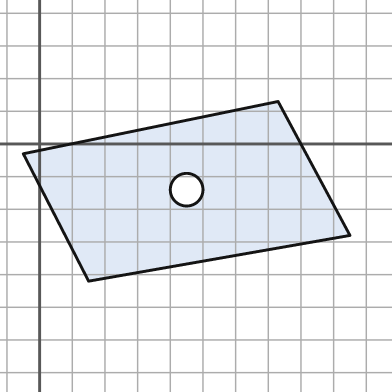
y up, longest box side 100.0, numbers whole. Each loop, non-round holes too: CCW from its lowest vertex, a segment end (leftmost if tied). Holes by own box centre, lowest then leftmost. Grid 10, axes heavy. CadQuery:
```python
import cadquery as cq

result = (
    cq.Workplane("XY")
    .moveTo(15.0, -42.0)
    .lineTo(95.0, -28.0)
    .lineTo(73.0, 13.0)
    .lineTo(-5.0, -3.0)
    .close()
    .moveTo(45.0, -14.0)
    .circle(5.0)
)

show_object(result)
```